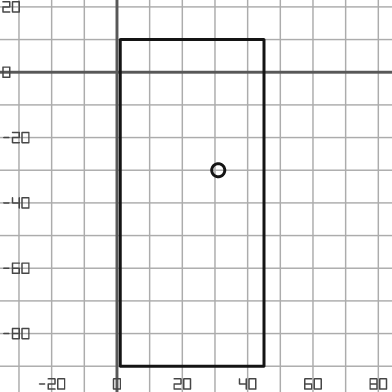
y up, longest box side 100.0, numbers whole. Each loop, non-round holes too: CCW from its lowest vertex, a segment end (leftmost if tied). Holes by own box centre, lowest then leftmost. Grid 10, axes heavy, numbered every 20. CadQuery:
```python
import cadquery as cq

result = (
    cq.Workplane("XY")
    .moveTo(1.0, -90.0)
    .lineTo(45.0, -90.0)
    .lineTo(45.0, 10.0)
    .lineTo(1.0, 10.0)
    .close()
    .moveTo(31.0, -30.0)
    .circle(2.0)
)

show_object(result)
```